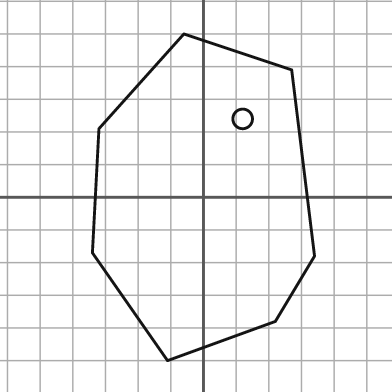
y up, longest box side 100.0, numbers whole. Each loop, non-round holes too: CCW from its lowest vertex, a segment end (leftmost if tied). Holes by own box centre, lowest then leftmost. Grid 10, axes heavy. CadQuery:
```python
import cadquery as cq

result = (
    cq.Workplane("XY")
    .moveTo(-11.0, -50.0)
    .lineTo(22.0, -38.0)
    .lineTo(34.0, -18.0)
    .lineTo(27.0, 39.0)
    .lineTo(-6.0, 50.0)
    .lineTo(-32.0, 21.0)
    .lineTo(-34.0, -17.0)
    .close()
    .moveTo(12.0, 24.0)
    .circle(3.0)
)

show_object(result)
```